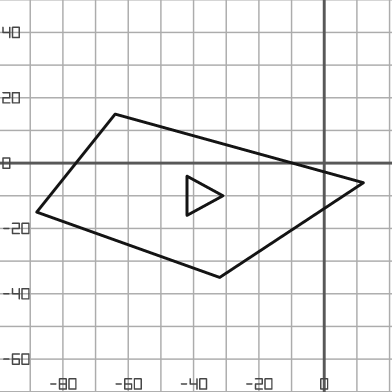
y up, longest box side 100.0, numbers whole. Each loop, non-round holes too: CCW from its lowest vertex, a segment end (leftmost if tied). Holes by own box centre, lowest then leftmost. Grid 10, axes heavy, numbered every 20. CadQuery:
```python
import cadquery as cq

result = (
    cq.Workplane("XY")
    .moveTo(-32.0, -35.0)
    .lineTo(12.0, -6.0)
    .lineTo(-64.0, 15.0)
    .lineTo(-88.0, -15.0)
    .close()
    .moveTo(-42.0, -16.0)
    .lineTo(-31.0, -10.0)
    .lineTo(-42.0, -4.0)
    .close()
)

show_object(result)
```